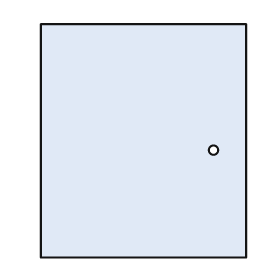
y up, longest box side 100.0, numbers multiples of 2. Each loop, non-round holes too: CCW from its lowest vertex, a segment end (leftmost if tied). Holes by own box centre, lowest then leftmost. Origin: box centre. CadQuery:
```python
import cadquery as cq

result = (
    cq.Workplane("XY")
    .moveTo(-44.0, -50.0)
    .lineTo(44.0, -50.0)
    .lineTo(44.0, 50.0)
    .lineTo(-44.0, 50.0)
    .close()
    .moveTo(30.0, -4.0)
    .circle(2.0)
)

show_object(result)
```